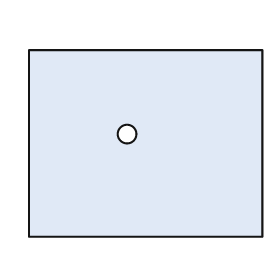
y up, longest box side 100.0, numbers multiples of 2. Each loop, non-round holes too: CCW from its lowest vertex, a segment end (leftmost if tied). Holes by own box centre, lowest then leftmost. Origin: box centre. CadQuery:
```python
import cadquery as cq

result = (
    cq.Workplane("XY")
    .moveTo(-50.0, -40.0)
    .lineTo(50.0, -40.0)
    .lineTo(50.0, 40.0)
    .lineTo(-50.0, 40.0)
    .close()
    .moveTo(-8.0, 4.0)
    .circle(4.0)
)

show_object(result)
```